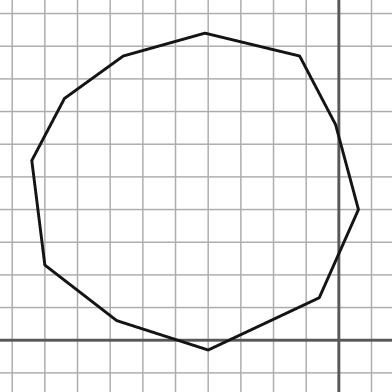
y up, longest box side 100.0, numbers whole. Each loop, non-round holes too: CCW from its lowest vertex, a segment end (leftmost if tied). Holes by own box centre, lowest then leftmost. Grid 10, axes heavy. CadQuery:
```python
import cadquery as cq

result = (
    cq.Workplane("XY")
    .moveTo(-40.0, -3.0)
    .lineTo(-6.0, 13.0)
    .lineTo(6.0, 40.0)
    .lineTo(-1.0, 66.0)
    .lineTo(-12.0, 87.0)
    .lineTo(-41.0, 94.0)
    .lineTo(-66.0, 87.0)
    .lineTo(-84.0, 74.0)
    .lineTo(-94.0, 55.0)
    .lineTo(-90.0, 23.0)
    .lineTo(-68.0, 6.0)
    .close()
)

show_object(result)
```